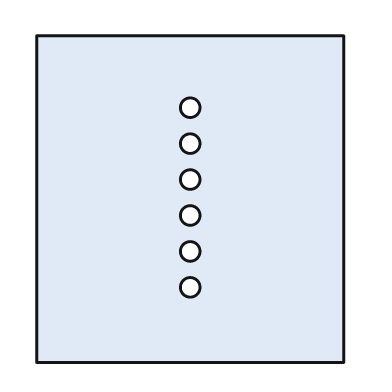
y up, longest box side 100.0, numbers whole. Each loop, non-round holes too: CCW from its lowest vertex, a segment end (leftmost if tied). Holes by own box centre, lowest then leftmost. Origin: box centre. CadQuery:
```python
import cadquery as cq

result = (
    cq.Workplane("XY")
    .moveTo(-47.0, -50.0)
    .lineTo(47.0, -50.0)
    .lineTo(47.0, 50.0)
    .lineTo(-47.0, 50.0)
    .close()
    .moveTo(0.0, -27.0)
    .circle(3.0)
    .moveTo(0.0, -16.0)
    .circle(3.0)
    .moveTo(0.0, -5.0)
    .circle(3.0)
    .moveTo(0.0, 6.0)
    .circle(3.0)
    .moveTo(0.0, 17.0)
    .circle(3.0)
    .moveTo(0.0, 28.0)
    .circle(3.0)
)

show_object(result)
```